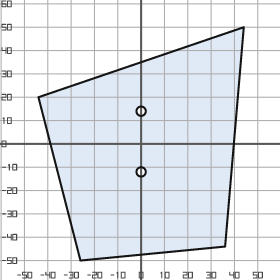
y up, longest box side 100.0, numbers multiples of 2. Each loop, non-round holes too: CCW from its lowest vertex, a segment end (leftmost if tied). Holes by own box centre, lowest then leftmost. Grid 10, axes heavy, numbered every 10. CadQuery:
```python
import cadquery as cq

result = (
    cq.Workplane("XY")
    .moveTo(-26.0, -50.0)
    .lineTo(36.0, -44.0)
    .lineTo(44.0, 50.0)
    .lineTo(-44.0, 20.0)
    .close()
    .moveTo(0.0, -12.0)
    .circle(2.0)
    .moveTo(0.0, 14.0)
    .circle(2.0)
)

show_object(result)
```